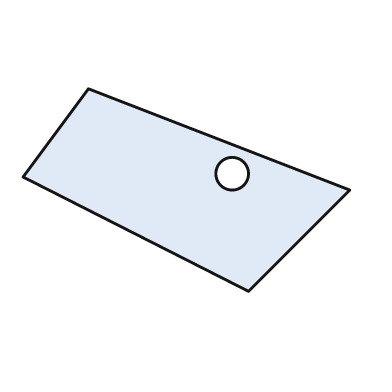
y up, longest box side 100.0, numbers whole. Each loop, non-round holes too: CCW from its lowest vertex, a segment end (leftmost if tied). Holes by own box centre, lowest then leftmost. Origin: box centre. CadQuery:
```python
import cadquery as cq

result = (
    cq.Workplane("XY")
    .moveTo(19.0, -31.0)
    .lineTo(50.0, 0.0)
    .lineTo(-30.0, 31.0)
    .lineTo(-50.0, 4.0)
    .close()
    .moveTo(14.0, 5.0)
    .circle(5.0)
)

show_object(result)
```